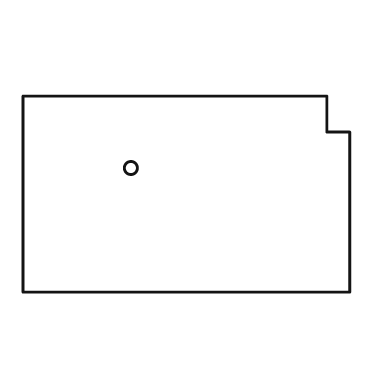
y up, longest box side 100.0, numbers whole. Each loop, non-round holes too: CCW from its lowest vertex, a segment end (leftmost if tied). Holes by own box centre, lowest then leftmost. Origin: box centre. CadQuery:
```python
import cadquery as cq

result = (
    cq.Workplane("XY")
    .moveTo(-50.0, -30.0)
    .lineTo(50.0, -30.0)
    .lineTo(50.0, 19.0)
    .lineTo(43.0, 19.0)
    .lineTo(43.0, 30.0)
    .lineTo(-50.0, 30.0)
    .close()
    .moveTo(-17.0, 8.0)
    .circle(2.0)
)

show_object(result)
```